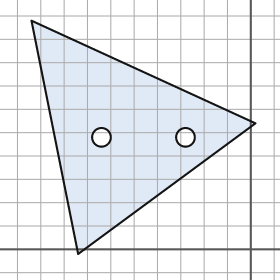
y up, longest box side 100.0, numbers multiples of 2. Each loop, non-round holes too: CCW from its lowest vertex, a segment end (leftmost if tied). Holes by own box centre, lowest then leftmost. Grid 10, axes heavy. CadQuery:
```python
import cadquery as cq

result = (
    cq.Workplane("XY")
    .moveTo(-74.0, -2.0)
    .lineTo(2.0, 54.0)
    .lineTo(-94.0, 98.0)
    .close()
    .moveTo(-64.0, 48.0)
    .circle(4.0)
    .moveTo(-28.0, 48.0)
    .circle(4.0)
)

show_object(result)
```